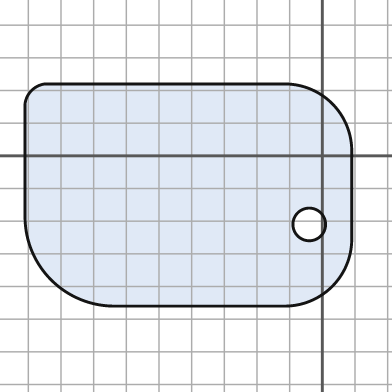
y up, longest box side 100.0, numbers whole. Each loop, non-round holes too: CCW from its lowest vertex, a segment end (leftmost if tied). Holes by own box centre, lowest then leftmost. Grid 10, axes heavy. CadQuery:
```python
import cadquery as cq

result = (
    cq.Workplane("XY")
    .moveTo(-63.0, -46.0)
    .lineTo(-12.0, -46.0)
    .threePointArc((3.0, -40.0), (9.0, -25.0))
    .lineTo(9.0, 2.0)
    .threePointArc((3.0, 16.0), (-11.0, 22.0))
    .lineTo(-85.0, 22.0)
    .threePointArc((-89.0, 20.0), (-91.0, 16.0))
    .lineTo(-91.0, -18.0)
    .threePointArc((-83.0, -38.0), (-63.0, -46.0))
    .close()
    .moveTo(-4.0, -21.0)
    .circle(5.0)
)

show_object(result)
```